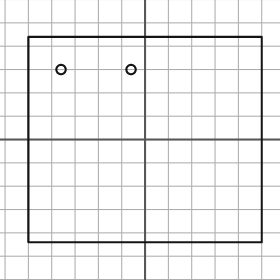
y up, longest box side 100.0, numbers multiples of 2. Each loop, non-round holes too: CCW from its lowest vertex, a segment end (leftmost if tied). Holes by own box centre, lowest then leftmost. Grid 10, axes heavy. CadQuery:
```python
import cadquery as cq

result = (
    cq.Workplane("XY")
    .moveTo(-50.0, -44.0)
    .lineTo(50.0, -44.0)
    .lineTo(50.0, 44.0)
    .lineTo(-50.0, 44.0)
    .close()
    .moveTo(-36.0, 30.0)
    .circle(2.0)
    .moveTo(-6.0, 30.0)
    .circle(2.0)
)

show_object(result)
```